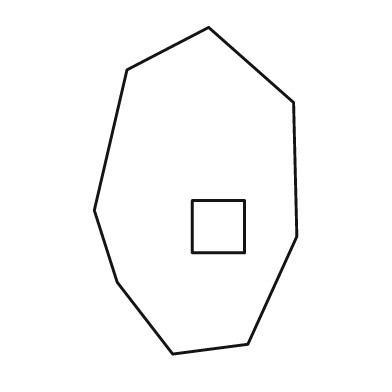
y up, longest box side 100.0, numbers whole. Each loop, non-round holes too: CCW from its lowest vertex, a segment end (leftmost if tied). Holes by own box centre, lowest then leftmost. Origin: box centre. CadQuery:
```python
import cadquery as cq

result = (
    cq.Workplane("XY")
    .moveTo(-7.0, -50.0)
    .lineTo(16.0, -47.0)
    .lineTo(31.0, -14.0)
    .lineTo(30.0, 27.0)
    .lineTo(4.0, 50.0)
    .lineTo(-21.0, 37.0)
    .lineTo(-31.0, -6.0)
    .lineTo(-24.0, -28.0)
    .close()
    .moveTo(-1.0, -19.0)
    .lineTo(15.0, -19.0)
    .lineTo(15.0, -3.0)
    .lineTo(-1.0, -3.0)
    .close()
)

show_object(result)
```